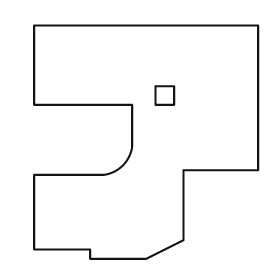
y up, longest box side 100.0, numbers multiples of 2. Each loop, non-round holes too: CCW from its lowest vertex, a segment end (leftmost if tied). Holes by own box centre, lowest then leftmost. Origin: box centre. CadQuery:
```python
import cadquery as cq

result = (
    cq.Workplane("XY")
    .moveTo(-24.0, -50.0)
    .lineTo(0.0, -50.0)
    .lineTo(16.0, -42.0)
    .lineTo(16.0, -12.0)
    .lineTo(48.0, -12.0)
    .lineTo(48.0, 50.0)
    .lineTo(-48.0, 50.0)
    .lineTo(-48.0, 16.0)
    .lineTo(-6.0, 16.0)
    .lineTo(-6.0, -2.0)
    .threePointArc((-10.0, -10.0), (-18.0, -14.0))
    .lineTo(-48.0, -14.0)
    .lineTo(-48.0, -46.0)
    .lineTo(-24.0, -46.0)
    .close()
    .moveTo(4.0, 16.0)
    .lineTo(12.0, 16.0)
    .lineTo(12.0, 24.0)
    .lineTo(4.0, 24.0)
    .close()
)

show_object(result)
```